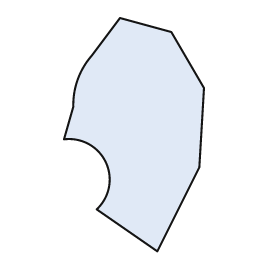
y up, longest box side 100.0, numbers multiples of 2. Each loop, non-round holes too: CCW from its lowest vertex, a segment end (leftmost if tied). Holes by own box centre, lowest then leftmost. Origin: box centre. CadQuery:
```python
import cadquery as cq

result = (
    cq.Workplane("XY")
    .moveTo(10.0, -50.0)
    .lineTo(28.0, -14.0)
    .lineTo(30.0, 20.0)
    .lineTo(16.0, 44.0)
    .lineTo(-6.0, 50.0)
    .lineTo(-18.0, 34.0)
    .threePointArc((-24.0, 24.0), (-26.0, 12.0))
    .lineTo(-30.0, -2.0)
    .threePointArc((-12.0, -12.0), (-16.0, -32.0))
    .close()
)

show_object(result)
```